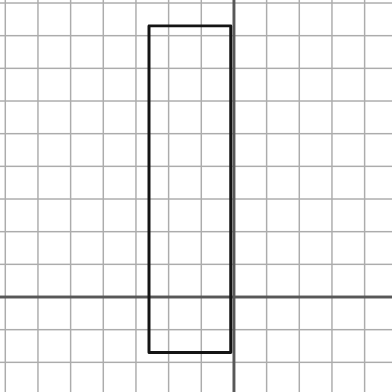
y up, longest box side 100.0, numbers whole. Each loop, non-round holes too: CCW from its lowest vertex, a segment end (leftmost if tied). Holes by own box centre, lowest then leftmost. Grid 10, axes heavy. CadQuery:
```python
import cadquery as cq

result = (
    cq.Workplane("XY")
    .moveTo(-26.0, -17.0)
    .lineTo(-1.0, -17.0)
    .lineTo(-1.0, 83.0)
    .lineTo(-26.0, 83.0)
    .close()
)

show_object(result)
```